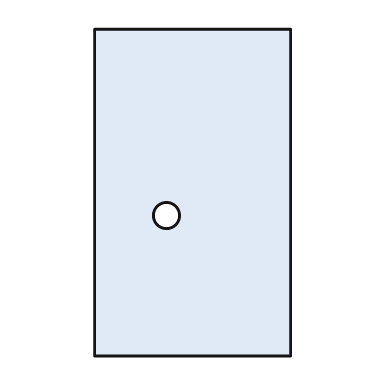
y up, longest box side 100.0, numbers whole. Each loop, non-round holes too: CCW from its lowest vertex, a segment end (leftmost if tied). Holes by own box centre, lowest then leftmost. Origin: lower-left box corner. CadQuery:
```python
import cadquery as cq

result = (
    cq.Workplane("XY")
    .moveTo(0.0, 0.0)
    .lineTo(60.0, 0.0)
    .lineTo(60.0, 100.0)
    .lineTo(0.0, 100.0)
    .close()
    .moveTo(22.0, 43.0)
    .circle(4.0)
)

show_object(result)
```